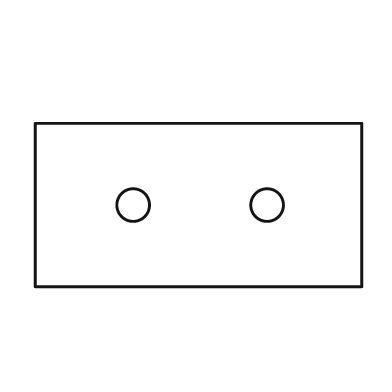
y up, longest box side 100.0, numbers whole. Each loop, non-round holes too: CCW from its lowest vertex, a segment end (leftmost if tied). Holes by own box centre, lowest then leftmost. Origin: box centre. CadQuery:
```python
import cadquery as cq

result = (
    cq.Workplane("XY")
    .moveTo(-50.0, -25.0)
    .lineTo(50.0, -25.0)
    .lineTo(50.0, 25.0)
    .lineTo(-50.0, 25.0)
    .close()
    .moveTo(-20.0, 0.0)
    .circle(5.0)
    .moveTo(21.0, 0.0)
    .circle(5.0)
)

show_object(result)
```